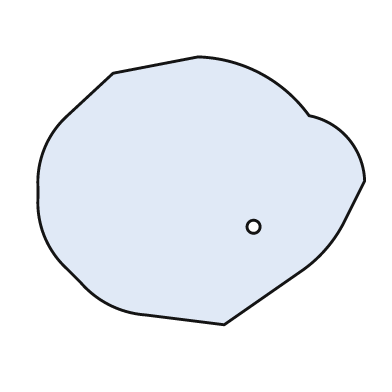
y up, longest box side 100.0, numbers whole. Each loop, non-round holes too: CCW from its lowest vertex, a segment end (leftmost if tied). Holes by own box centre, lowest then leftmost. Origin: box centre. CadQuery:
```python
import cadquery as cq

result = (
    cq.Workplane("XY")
    .moveTo(7.0, -41.0)
    .lineTo(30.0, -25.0)
    .threePointArc((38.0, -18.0), (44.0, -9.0))
    .lineTo(50.0, 3.0)
    .threePointArc((45.0, 16.0), (33.0, 23.0))
    .threePointArc((18.0, 36.0), (-1.0, 41.0))
    .lineTo(-27.0, 36.0)
    .lineTo(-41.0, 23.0)
    .threePointArc((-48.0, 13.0), (-50.0, 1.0))
    .lineTo(-50.0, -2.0)
    .threePointArc((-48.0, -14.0), (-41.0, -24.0))
    .lineTo(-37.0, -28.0)
    .threePointArc((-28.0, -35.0), (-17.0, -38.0))
    .close()
    .moveTo(16.0, -11.0)
    .circle(2.0)
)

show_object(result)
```